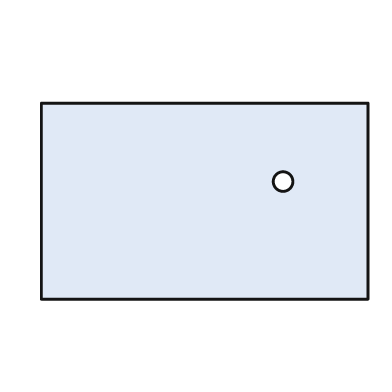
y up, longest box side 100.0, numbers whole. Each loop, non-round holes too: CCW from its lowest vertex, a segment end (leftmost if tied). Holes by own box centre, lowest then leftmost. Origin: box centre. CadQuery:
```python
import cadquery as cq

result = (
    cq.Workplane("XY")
    .moveTo(-50.0, -30.0)
    .lineTo(50.0, -30.0)
    .lineTo(50.0, 30.0)
    .lineTo(-50.0, 30.0)
    .close()
    .moveTo(24.0, 6.0)
    .circle(3.0)
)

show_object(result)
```